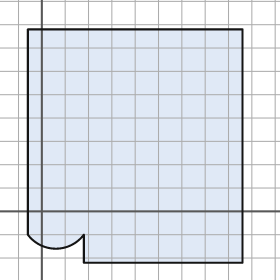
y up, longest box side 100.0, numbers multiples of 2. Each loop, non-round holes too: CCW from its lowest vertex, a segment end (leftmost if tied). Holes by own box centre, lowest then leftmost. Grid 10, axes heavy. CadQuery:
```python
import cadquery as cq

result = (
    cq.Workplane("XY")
    .moveTo(18.0, -22.0)
    .lineTo(86.0, -22.0)
    .lineTo(86.0, 78.0)
    .lineTo(-6.0, 78.0)
    .lineTo(-6.0, -10.0)
    .threePointArc((6.0, -16.0), (18.0, -10.0))
    .close()
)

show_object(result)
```